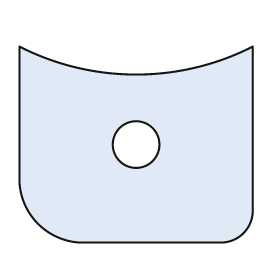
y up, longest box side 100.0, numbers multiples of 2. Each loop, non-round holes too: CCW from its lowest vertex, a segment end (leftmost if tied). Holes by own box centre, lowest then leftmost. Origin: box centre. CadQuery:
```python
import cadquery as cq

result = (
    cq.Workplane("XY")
    .moveTo(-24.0, -42.0)
    .lineTo(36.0, -42.0)
    .threePointArc((46.0, -38.0), (50.0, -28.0))
    .lineTo(50.0, 42.0)
    .threePointArc((0.0, 30.0), (-50.0, 42.0))
    .lineTo(-50.0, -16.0)
    .threePointArc((-42.0, -34.0), (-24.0, -42.0))
    .close()
    .moveTo(0.0, 0.0)
    .circle(10.0)
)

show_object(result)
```